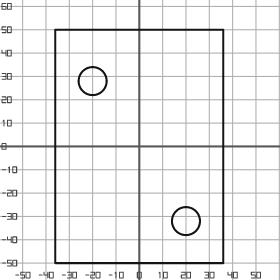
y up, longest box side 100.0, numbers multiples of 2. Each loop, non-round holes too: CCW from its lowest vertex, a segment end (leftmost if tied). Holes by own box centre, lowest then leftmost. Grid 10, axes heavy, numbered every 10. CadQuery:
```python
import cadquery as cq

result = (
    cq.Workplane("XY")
    .moveTo(-36.0, -50.0)
    .lineTo(36.0, -50.0)
    .lineTo(36.0, 50.0)
    .lineTo(-36.0, 50.0)
    .close()
    .moveTo(20.0, -32.0)
    .circle(6.0)
    .moveTo(-20.0, 28.0)
    .circle(6.0)
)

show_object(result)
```